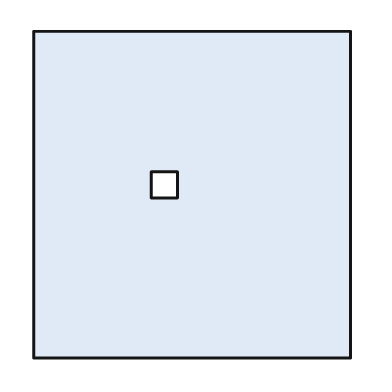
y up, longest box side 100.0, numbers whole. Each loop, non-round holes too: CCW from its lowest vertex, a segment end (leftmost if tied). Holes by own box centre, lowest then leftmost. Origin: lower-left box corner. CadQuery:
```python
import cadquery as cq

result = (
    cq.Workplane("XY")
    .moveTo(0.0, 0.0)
    .lineTo(97.0, 0.0)
    .lineTo(97.0, 100.0)
    .lineTo(0.0, 100.0)
    .close()
    .moveTo(36.0, 49.0)
    .lineTo(44.0, 49.0)
    .lineTo(44.0, 57.0)
    .lineTo(36.0, 57.0)
    .close()
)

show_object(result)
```